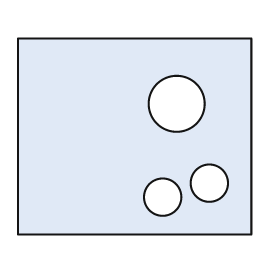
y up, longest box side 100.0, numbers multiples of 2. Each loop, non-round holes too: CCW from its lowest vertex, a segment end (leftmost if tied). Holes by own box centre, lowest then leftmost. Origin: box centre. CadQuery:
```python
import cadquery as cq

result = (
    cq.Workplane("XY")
    .moveTo(-50.0, -42.0)
    .lineTo(50.0, -42.0)
    .lineTo(50.0, 42.0)
    .lineTo(-50.0, 42.0)
    .close()
    .moveTo(12.0, -26.0)
    .circle(8.0)
    .moveTo(32.0, -20.0)
    .circle(8.0)
    .moveTo(18.0, 14.0)
    .circle(12.0)
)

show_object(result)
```